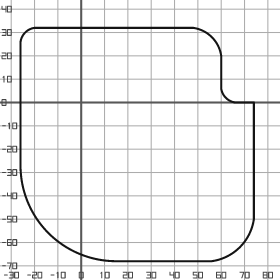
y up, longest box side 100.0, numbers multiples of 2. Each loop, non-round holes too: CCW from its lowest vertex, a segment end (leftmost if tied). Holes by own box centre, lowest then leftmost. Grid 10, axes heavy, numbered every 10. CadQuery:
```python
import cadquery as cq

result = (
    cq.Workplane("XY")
    .moveTo(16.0, -68.0)
    .lineTo(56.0, -68.0)
    .threePointArc((68.0, -62.0), (74.0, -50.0))
    .lineTo(74.0, 0.0)
    .lineTo(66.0, 0.0)
    .threePointArc((62.0, 2.0), (60.0, 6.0))
    .lineTo(60.0, 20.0)
    .threePointArc((56.0, 28.0), (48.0, 32.0))
    .lineTo(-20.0, 32.0)
    .threePointArc((-24.0, 30.0), (-26.0, 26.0))
    .lineTo(-26.0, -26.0)
    .threePointArc((-14.0, -56.0), (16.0, -68.0))
    .close()
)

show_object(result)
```